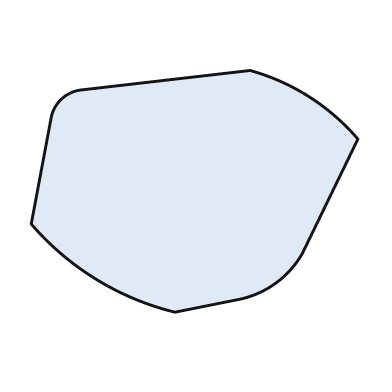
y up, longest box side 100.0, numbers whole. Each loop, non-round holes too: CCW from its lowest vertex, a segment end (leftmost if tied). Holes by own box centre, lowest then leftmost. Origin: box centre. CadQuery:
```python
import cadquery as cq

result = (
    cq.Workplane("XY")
    .moveTo(-6.0, -37.0)
    .lineTo(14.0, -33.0)
    .threePointArc((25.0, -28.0), (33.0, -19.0))
    .lineTo(50.0, 16.0)
    .threePointArc((35.0, 29.0), (17.0, 37.0))
    .lineTo(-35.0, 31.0)
    .threePointArc((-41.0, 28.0), (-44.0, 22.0))
    .lineTo(-50.0, -10.0)
    .threePointArc((-30.0, -27.0), (-6.0, -37.0))
    .close()
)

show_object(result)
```